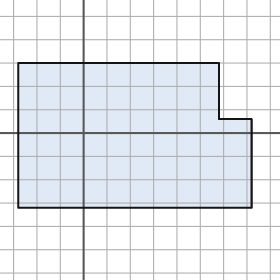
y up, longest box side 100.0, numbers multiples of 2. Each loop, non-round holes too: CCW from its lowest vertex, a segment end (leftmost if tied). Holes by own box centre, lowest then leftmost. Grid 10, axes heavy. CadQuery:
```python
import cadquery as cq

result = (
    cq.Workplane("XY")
    .moveTo(-28.0, -32.0)
    .lineTo(72.0, -32.0)
    .lineTo(72.0, 6.0)
    .lineTo(58.0, 6.0)
    .lineTo(58.0, 30.0)
    .lineTo(-28.0, 30.0)
    .close()
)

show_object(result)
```